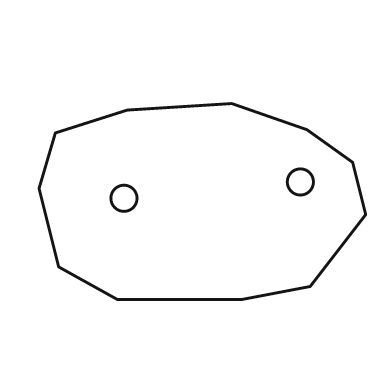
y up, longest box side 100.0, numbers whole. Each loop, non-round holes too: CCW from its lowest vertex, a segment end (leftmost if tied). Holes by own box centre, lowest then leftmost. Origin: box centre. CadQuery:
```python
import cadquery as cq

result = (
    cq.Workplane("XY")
    .moveTo(-26.0, -30.0)
    .lineTo(12.0, -30.0)
    .lineTo(33.0, -26.0)
    .lineTo(50.0, -4.0)
    .lineTo(46.0, 12.0)
    .lineTo(32.0, 22.0)
    .lineTo(9.0, 30.0)
    .lineTo(-23.0, 28.0)
    .lineTo(-45.0, 21.0)
    .lineTo(-50.0, 4.0)
    .lineTo(-44.0, -20.0)
    .close()
    .moveTo(-24.0, 1.0)
    .circle(4.0)
    .moveTo(30.0, 6.0)
    .circle(4.0)
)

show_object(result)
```